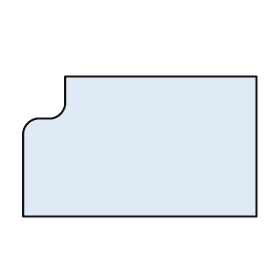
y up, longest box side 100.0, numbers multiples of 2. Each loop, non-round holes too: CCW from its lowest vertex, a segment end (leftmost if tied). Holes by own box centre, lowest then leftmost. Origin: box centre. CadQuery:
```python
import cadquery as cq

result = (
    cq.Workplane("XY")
    .moveTo(-50.0, -30.0)
    .lineTo(50.0, -30.0)
    .lineTo(50.0, 30.0)
    .lineTo(-32.0, 30.0)
    .lineTo(-32.0, 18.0)
    .threePointArc((-34.0, 14.0), (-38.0, 12.0))
    .lineTo(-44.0, 12.0)
    .threePointArc((-48.0, 10.0), (-50.0, 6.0))
    .close()
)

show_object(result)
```